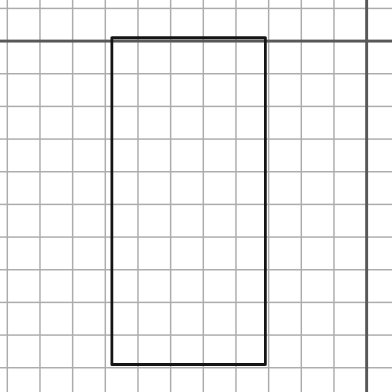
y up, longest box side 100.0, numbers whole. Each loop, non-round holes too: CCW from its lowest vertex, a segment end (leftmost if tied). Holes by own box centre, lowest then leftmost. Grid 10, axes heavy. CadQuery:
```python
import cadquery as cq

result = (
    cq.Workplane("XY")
    .moveTo(-78.0, -99.0)
    .lineTo(-31.0, -99.0)
    .lineTo(-31.0, 1.0)
    .lineTo(-78.0, 1.0)
    .close()
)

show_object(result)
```